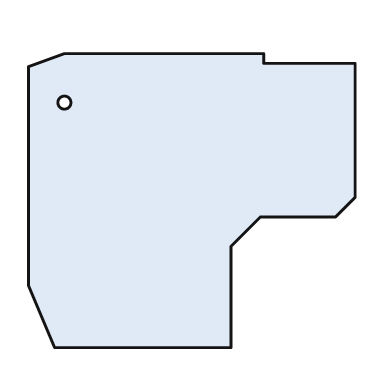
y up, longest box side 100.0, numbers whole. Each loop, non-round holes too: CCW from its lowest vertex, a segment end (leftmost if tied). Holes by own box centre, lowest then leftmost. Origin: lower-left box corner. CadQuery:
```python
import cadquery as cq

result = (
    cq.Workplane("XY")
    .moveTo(8.0, 0.0)
    .lineTo(62.0, 0.0)
    .lineTo(62.0, 31.0)
    .lineTo(71.0, 40.0)
    .lineTo(94.0, 40.0)
    .lineTo(100.0, 46.0)
    .lineTo(100.0, 87.0)
    .lineTo(72.0, 87.0)
    .lineTo(72.0, 90.0)
    .lineTo(11.0, 90.0)
    .lineTo(0.0, 86.0)
    .lineTo(0.0, 19.0)
    .close()
    .moveTo(11.0, 75.0)
    .circle(2.0)
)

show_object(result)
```